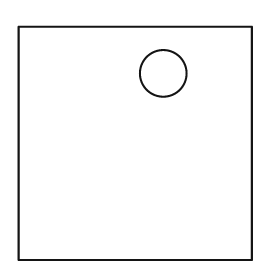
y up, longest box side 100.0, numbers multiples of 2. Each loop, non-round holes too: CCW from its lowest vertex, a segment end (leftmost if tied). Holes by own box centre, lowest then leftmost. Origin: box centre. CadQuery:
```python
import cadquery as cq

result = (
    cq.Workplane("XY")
    .moveTo(-50.0, -50.0)
    .lineTo(50.0, -50.0)
    .lineTo(50.0, 50.0)
    .lineTo(-50.0, 50.0)
    .close()
    .moveTo(12.0, 30.0)
    .circle(10.0)
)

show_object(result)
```